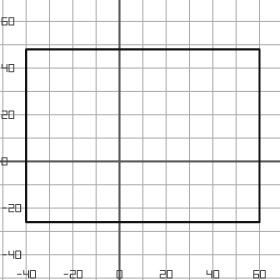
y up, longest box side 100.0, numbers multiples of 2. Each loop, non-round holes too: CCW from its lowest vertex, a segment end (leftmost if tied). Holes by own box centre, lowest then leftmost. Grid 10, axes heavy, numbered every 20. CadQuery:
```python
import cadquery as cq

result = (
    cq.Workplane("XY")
    .moveTo(-40.0, -26.0)
    .lineTo(60.0, -26.0)
    .lineTo(60.0, 48.0)
    .lineTo(-40.0, 48.0)
    .close()
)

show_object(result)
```